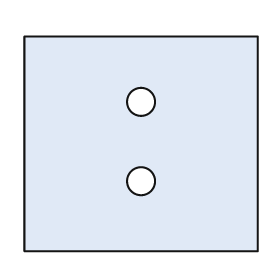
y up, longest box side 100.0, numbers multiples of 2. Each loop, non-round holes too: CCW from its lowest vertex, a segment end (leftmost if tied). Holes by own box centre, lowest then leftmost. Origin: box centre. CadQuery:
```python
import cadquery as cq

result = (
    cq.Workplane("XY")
    .moveTo(-50.0, -46.0)
    .lineTo(50.0, -46.0)
    .lineTo(50.0, 46.0)
    .lineTo(-50.0, 46.0)
    .close()
    .moveTo(0.0, -16.0)
    .circle(6.0)
    .moveTo(0.0, 18.0)
    .circle(6.0)
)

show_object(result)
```